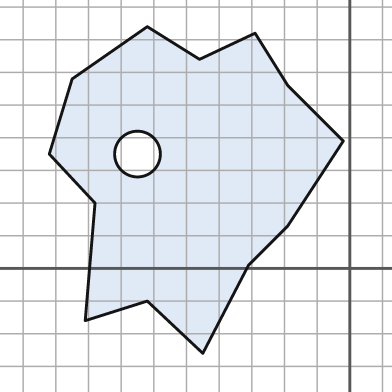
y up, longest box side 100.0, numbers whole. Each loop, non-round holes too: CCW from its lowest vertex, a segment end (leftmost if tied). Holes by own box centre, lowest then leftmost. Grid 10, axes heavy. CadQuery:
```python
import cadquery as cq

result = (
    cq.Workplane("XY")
    .moveTo(-45.0, -26.0)
    .lineTo(-31.0, 1.0)
    .lineTo(-19.0, 13.0)
    .lineTo(-2.0, 39.0)
    .lineTo(-19.0, 56.0)
    .lineTo(-29.0, 72.0)
    .lineTo(-46.0, 64.0)
    .lineTo(-62.0, 74.0)
    .lineTo(-85.0, 58.0)
    .lineTo(-92.0, 35.0)
    .lineTo(-78.0, 20.0)
    .lineTo(-81.0, -16.0)
    .lineTo(-62.0, -10.0)
    .close()
    .moveTo(-65.0, 35.0)
    .circle(7.0)
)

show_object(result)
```